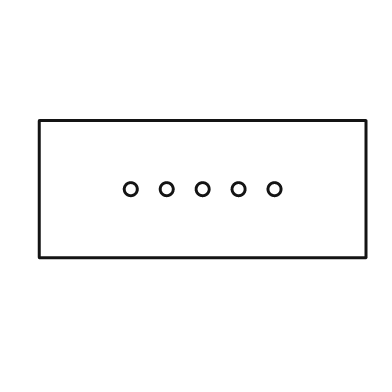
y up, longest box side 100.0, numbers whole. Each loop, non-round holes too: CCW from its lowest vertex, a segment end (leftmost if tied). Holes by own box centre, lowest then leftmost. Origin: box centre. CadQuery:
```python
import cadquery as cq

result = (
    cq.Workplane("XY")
    .moveTo(-50.0, -21.0)
    .lineTo(50.0, -21.0)
    .lineTo(50.0, 21.0)
    .lineTo(-50.0, 21.0)
    .close()
    .moveTo(-22.0, 0.0)
    .circle(2.0)
    .moveTo(-11.0, 0.0)
    .circle(2.0)
    .moveTo(0.0, 0.0)
    .circle(2.0)
    .moveTo(11.0, 0.0)
    .circle(2.0)
    .moveTo(22.0, 0.0)
    .circle(2.0)
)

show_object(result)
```